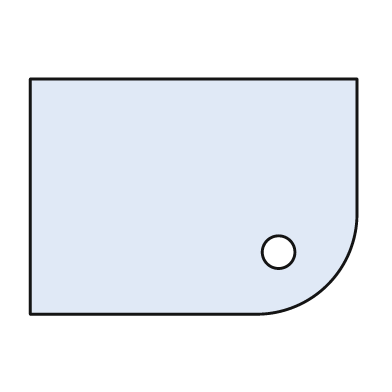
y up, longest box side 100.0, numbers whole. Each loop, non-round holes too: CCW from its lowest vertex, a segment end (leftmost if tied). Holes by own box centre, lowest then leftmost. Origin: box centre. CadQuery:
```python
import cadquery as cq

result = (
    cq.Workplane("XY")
    .moveTo(-50.0, -36.0)
    .lineTo(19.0, -36.0)
    .threePointArc((41.0, -27.0), (50.0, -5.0))
    .lineTo(50.0, 36.0)
    .lineTo(-50.0, 36.0)
    .close()
    .moveTo(26.0, -17.0)
    .circle(5.0)
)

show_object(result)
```